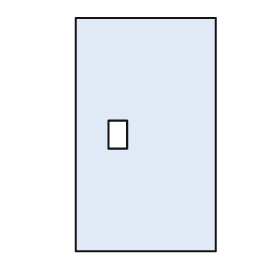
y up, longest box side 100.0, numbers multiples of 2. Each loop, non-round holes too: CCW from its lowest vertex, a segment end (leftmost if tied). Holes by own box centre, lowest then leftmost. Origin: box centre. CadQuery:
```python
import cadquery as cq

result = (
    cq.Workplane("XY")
    .moveTo(-30.0, -50.0)
    .lineTo(30.0, -50.0)
    .lineTo(30.0, 50.0)
    .lineTo(-30.0, 50.0)
    .close()
    .moveTo(-16.0, -6.0)
    .lineTo(-8.0, -6.0)
    .lineTo(-8.0, 6.0)
    .lineTo(-16.0, 6.0)
    .close()
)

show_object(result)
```